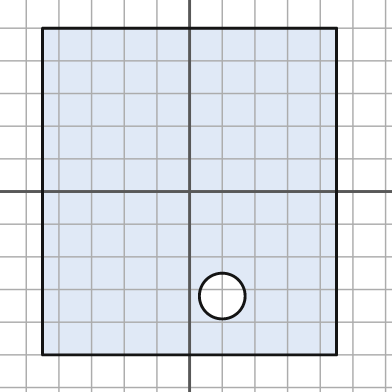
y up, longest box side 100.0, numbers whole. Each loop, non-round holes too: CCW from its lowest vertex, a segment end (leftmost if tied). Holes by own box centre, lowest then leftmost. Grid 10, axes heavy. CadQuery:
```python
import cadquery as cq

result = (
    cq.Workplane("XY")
    .moveTo(-45.0, -50.0)
    .lineTo(45.0, -50.0)
    .lineTo(45.0, 50.0)
    .lineTo(-45.0, 50.0)
    .close()
    .moveTo(10.0, -32.0)
    .circle(7.0)
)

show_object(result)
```